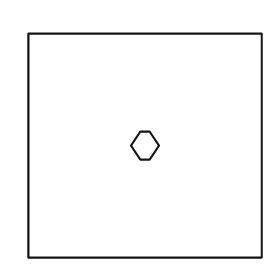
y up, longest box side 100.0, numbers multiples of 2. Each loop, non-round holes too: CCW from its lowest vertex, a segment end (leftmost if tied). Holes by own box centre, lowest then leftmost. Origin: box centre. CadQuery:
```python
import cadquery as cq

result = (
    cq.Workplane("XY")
    .moveTo(-50.0, -48.0)
    .lineTo(50.0, -48.0)
    .lineTo(50.0, 48.0)
    .lineTo(-50.0, 48.0)
    .close()
    .moveTo(-2.0, -6.0)
    .lineTo(2.0, -6.0)
    .lineTo(6.0, 0.0)
    .lineTo(2.0, 6.0)
    .lineTo(-2.0, 6.0)
    .lineTo(-6.0, 0.0)
    .close()
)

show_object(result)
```